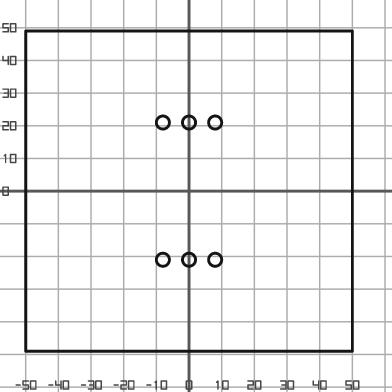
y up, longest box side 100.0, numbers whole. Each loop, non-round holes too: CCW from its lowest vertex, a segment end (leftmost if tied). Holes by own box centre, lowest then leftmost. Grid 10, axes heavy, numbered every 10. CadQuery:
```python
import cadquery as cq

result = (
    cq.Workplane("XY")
    .moveTo(-50.0, -49.0)
    .lineTo(50.0, -49.0)
    .lineTo(50.0, 49.0)
    .lineTo(-50.0, 49.0)
    .close()
    .moveTo(-8.0, -21.0)
    .circle(2.0)
    .moveTo(0.0, -21.0)
    .circle(2.0)
    .moveTo(8.0, -21.0)
    .circle(2.0)
    .moveTo(-8.0, 21.0)
    .circle(2.0)
    .moveTo(0.0, 21.0)
    .circle(2.0)
    .moveTo(8.0, 21.0)
    .circle(2.0)
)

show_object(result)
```